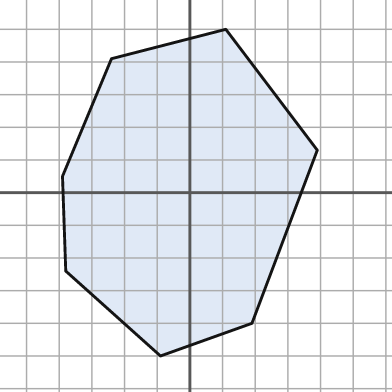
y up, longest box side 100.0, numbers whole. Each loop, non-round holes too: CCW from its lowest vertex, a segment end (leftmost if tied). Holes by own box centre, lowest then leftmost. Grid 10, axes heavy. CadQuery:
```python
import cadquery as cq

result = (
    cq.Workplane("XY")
    .moveTo(-9.0, -50.0)
    .lineTo(19.0, -40.0)
    .lineTo(39.0, 13.0)
    .lineTo(11.0, 50.0)
    .lineTo(-24.0, 41.0)
    .lineTo(-39.0, 5.0)
    .lineTo(-38.0, -24.0)
    .close()
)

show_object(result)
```